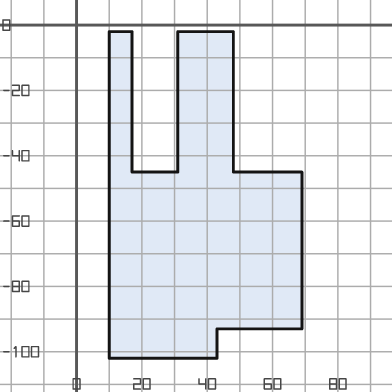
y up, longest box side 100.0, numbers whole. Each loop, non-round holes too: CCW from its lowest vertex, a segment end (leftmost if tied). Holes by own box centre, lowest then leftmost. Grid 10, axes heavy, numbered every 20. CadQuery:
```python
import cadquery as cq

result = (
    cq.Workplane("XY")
    .moveTo(10.0, -102.0)
    .lineTo(43.0, -102.0)
    .lineTo(43.0, -93.0)
    .lineTo(69.0, -93.0)
    .lineTo(69.0, -45.0)
    .lineTo(48.0, -45.0)
    .lineTo(48.0, -2.0)
    .lineTo(31.0, -2.0)
    .lineTo(31.0, -45.0)
    .lineTo(17.0, -45.0)
    .lineTo(17.0, -2.0)
    .lineTo(10.0, -2.0)
    .close()
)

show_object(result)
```